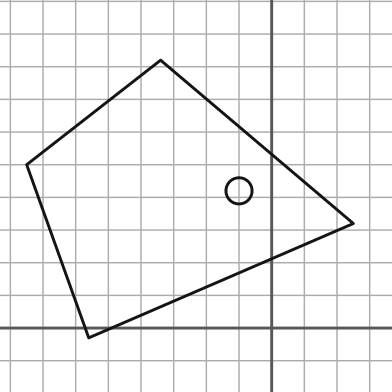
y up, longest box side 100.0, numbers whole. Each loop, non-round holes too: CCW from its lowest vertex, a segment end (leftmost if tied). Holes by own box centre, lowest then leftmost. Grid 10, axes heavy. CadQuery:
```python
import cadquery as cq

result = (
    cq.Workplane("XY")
    .moveTo(-56.0, -3.0)
    .lineTo(25.0, 32.0)
    .lineTo(-34.0, 82.0)
    .lineTo(-75.0, 50.0)
    .close()
    .moveTo(-10.0, 42.0)
    .circle(4.0)
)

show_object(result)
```